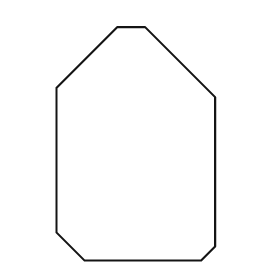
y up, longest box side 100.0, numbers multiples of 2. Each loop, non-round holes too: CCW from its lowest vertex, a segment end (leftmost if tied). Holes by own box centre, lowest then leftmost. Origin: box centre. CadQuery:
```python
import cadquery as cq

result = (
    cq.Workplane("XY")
    .moveTo(-22.0, -50.0)
    .lineTo(28.0, -50.0)
    .lineTo(34.0, -44.0)
    .lineTo(34.0, 20.0)
    .lineTo(4.0, 50.0)
    .lineTo(-8.0, 50.0)
    .lineTo(-34.0, 24.0)
    .lineTo(-34.0, -38.0)
    .close()
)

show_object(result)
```